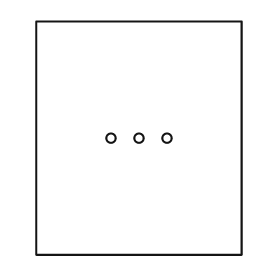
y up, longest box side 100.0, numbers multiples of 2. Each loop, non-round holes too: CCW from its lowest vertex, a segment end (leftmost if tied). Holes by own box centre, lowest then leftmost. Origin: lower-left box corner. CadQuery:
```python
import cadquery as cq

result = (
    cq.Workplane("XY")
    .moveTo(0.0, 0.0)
    .lineTo(88.0, 0.0)
    .lineTo(88.0, 100.0)
    .lineTo(0.0, 100.0)
    .close()
    .moveTo(32.0, 50.0)
    .circle(2.0)
    .moveTo(44.0, 50.0)
    .circle(2.0)
    .moveTo(56.0, 50.0)
    .circle(2.0)
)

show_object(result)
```